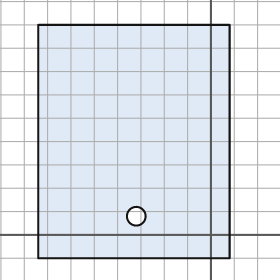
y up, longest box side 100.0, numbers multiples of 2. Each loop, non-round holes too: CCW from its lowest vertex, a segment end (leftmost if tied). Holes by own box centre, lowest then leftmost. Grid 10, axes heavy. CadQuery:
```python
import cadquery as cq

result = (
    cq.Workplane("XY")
    .moveTo(-74.0, -10.0)
    .lineTo(8.0, -10.0)
    .lineTo(8.0, 90.0)
    .lineTo(-74.0, 90.0)
    .close()
    .moveTo(-32.0, 8.0)
    .circle(4.0)
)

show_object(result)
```